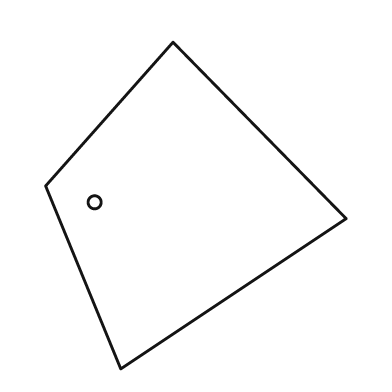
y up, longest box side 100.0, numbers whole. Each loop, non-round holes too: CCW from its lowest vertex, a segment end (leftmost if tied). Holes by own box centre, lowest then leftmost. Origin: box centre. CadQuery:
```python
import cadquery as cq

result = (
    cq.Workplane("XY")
    .moveTo(-23.0, -50.0)
    .lineTo(46.0, -4.0)
    .lineTo(-7.0, 50.0)
    .lineTo(-46.0, 6.0)
    .close()
    .moveTo(-31.0, 1.0)
    .circle(2.0)
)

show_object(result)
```